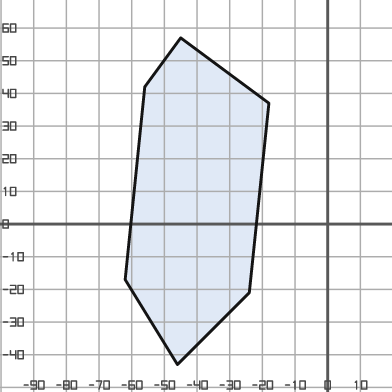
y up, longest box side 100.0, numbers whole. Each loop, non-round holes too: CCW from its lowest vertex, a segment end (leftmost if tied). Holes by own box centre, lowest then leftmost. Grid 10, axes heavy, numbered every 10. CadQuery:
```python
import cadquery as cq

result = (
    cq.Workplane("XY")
    .moveTo(-46.0, -43.0)
    .lineTo(-24.0, -21.0)
    .lineTo(-18.0, 37.0)
    .lineTo(-45.0, 57.0)
    .lineTo(-56.0, 42.0)
    .lineTo(-62.0, -17.0)
    .close()
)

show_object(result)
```